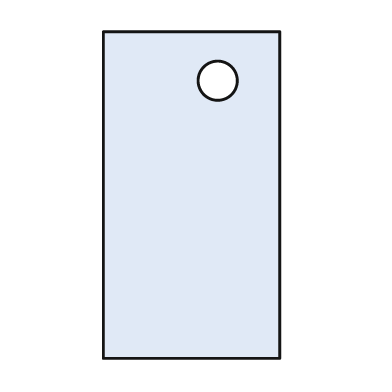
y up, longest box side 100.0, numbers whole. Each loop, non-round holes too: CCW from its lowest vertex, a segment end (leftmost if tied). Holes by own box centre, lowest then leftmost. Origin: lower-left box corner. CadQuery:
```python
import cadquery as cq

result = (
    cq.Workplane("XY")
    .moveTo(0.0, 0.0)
    .lineTo(54.0, 0.0)
    .lineTo(54.0, 100.0)
    .lineTo(0.0, 100.0)
    .close()
    .moveTo(35.0, 85.0)
    .circle(6.0)
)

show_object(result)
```